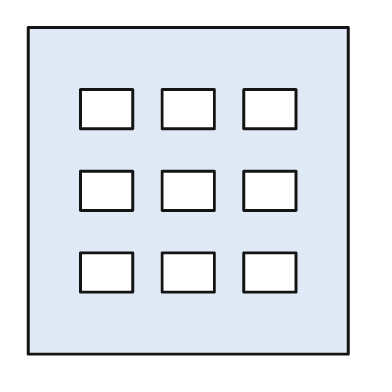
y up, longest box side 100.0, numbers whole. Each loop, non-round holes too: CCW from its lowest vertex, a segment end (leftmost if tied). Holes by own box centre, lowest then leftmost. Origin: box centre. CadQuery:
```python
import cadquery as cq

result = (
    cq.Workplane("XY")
    .moveTo(-49.0, -50.0)
    .lineTo(49.0, -50.0)
    .lineTo(49.0, 50.0)
    .lineTo(-49.0, 50.0)
    .close()
    .moveTo(-33.0, -31.0)
    .lineTo(-17.0, -31.0)
    .lineTo(-17.0, -19.0)
    .lineTo(-33.0, -19.0)
    .close()
    .moveTo(-8.0, -31.0)
    .lineTo(8.0, -31.0)
    .lineTo(8.0, -19.0)
    .lineTo(-8.0, -19.0)
    .close()
    .moveTo(17.0, -31.0)
    .lineTo(33.0, -31.0)
    .lineTo(33.0, -19.0)
    .lineTo(17.0, -19.0)
    .close()
    .moveTo(-33.0, -6.0)
    .lineTo(-17.0, -6.0)
    .lineTo(-17.0, 6.0)
    .lineTo(-33.0, 6.0)
    .close()
    .moveTo(-8.0, -6.0)
    .lineTo(8.0, -6.0)
    .lineTo(8.0, 6.0)
    .lineTo(-8.0, 6.0)
    .close()
    .moveTo(17.0, -6.0)
    .lineTo(33.0, -6.0)
    .lineTo(33.0, 6.0)
    .lineTo(17.0, 6.0)
    .close()
    .moveTo(-33.0, 19.0)
    .lineTo(-17.0, 19.0)
    .lineTo(-17.0, 31.0)
    .lineTo(-33.0, 31.0)
    .close()
    .moveTo(-8.0, 19.0)
    .lineTo(8.0, 19.0)
    .lineTo(8.0, 31.0)
    .lineTo(-8.0, 31.0)
    .close()
    .moveTo(17.0, 19.0)
    .lineTo(33.0, 19.0)
    .lineTo(33.0, 31.0)
    .lineTo(17.0, 31.0)
    .close()
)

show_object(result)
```